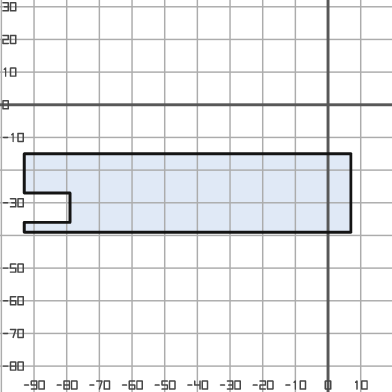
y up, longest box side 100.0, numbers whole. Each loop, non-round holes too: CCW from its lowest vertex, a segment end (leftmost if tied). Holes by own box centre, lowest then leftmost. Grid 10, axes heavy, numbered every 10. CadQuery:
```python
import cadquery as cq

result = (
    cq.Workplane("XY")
    .moveTo(-93.0, -39.0)
    .lineTo(7.0, -39.0)
    .lineTo(7.0, -15.0)
    .lineTo(-93.0, -15.0)
    .lineTo(-93.0, -27.0)
    .lineTo(-79.0, -27.0)
    .lineTo(-79.0, -36.0)
    .lineTo(-93.0, -36.0)
    .close()
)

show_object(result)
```